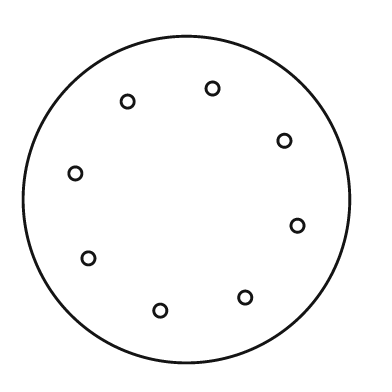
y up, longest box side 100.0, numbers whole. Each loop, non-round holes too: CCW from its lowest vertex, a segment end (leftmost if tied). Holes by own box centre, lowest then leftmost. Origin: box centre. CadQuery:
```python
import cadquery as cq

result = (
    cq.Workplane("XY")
    .moveTo(0.0, 0.0)
    .circle(50.0)
    .moveTo(-8.0, -34.0)
    .circle(2.0)
    .moveTo(18.0, -30.0)
    .circle(2.0)
    .moveTo(-30.0, -18.0)
    .circle(2.0)
    .moveTo(34.0, -8.0)
    .circle(2.0)
    .moveTo(-34.0, 8.0)
    .circle(2.0)
    .moveTo(30.0, 18.0)
    .circle(2.0)
    .moveTo(-18.0, 30.0)
    .circle(2.0)
    .moveTo(8.0, 34.0)
    .circle(2.0)
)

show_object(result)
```